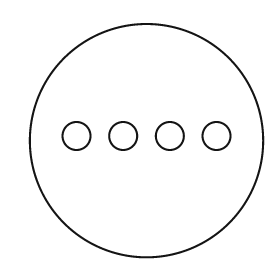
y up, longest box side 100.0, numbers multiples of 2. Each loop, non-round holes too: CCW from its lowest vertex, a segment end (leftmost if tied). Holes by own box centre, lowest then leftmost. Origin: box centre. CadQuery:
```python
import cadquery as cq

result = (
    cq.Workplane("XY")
    .moveTo(0.0, 0.0)
    .circle(50.0)
    .moveTo(-30.0, 2.0)
    .circle(6.0)
    .moveTo(-10.0, 2.0)
    .circle(6.0)
    .moveTo(10.0, 2.0)
    .circle(6.0)
    .moveTo(30.0, 2.0)
    .circle(6.0)
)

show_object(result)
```